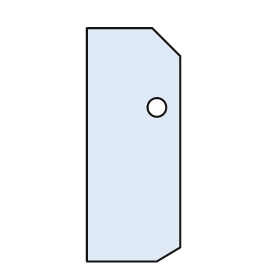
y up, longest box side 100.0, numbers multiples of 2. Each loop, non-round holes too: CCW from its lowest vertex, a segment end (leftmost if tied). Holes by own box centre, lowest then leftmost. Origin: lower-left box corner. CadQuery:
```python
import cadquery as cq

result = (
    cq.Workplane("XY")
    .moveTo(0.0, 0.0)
    .lineTo(30.0, 0.0)
    .lineTo(40.0, 6.0)
    .lineTo(40.0, 88.0)
    .lineTo(28.0, 100.0)
    .lineTo(0.0, 100.0)
    .close()
    .moveTo(30.0, 66.0)
    .circle(4.0)
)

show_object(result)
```